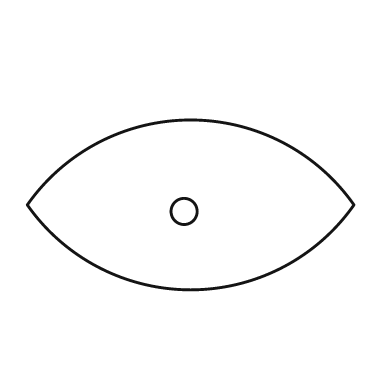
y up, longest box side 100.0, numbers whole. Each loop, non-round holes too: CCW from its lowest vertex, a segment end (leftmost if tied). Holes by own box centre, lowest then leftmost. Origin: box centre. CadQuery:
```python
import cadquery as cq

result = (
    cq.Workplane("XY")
    .moveTo(-50.0, 0.0)
    .threePointArc((0.0, -26.0), (50.0, 0.0))
    .threePointArc((0.0, 26.0), (-50.0, 0.0))
    .close()
    .moveTo(-2.0, -2.0)
    .circle(4.0)
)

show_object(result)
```